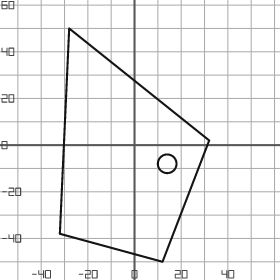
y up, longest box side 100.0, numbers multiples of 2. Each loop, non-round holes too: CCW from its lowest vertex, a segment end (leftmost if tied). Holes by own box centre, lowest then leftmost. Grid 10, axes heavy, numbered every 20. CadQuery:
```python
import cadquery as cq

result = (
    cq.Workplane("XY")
    .moveTo(12.0, -50.0)
    .lineTo(32.0, 2.0)
    .lineTo(-28.0, 50.0)
    .lineTo(-32.0, -38.0)
    .close()
    .moveTo(14.0, -8.0)
    .circle(4.0)
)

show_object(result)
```